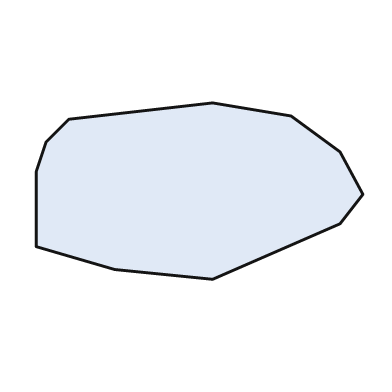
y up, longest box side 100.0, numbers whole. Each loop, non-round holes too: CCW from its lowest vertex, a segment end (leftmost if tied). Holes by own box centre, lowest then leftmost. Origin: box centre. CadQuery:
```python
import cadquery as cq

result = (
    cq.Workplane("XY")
    .moveTo(4.0, -27.0)
    .lineTo(43.0, -10.0)
    .lineTo(50.0, -1.0)
    .lineTo(43.0, 12.0)
    .lineTo(28.0, 23.0)
    .lineTo(4.0, 27.0)
    .lineTo(-40.0, 22.0)
    .lineTo(-47.0, 15.0)
    .lineTo(-50.0, 6.0)
    .lineTo(-50.0, -17.0)
    .lineTo(-26.0, -24.0)
    .close()
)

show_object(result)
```